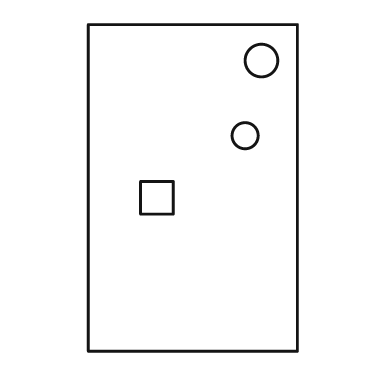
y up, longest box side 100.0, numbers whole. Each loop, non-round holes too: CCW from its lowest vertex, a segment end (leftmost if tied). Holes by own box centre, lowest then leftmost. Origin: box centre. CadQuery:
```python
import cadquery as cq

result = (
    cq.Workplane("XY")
    .moveTo(-32.0, -50.0)
    .lineTo(32.0, -50.0)
    .lineTo(32.0, 50.0)
    .lineTo(-32.0, 50.0)
    .close()
    .moveTo(-16.0, -8.0)
    .lineTo(-6.0, -8.0)
    .lineTo(-6.0, 2.0)
    .lineTo(-16.0, 2.0)
    .close()
    .moveTo(16.0, 16.0)
    .circle(4.0)
    .moveTo(21.0, 39.0)
    .circle(5.0)
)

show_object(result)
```